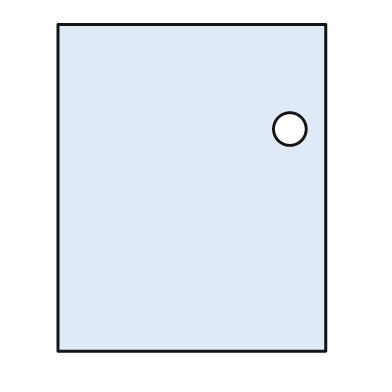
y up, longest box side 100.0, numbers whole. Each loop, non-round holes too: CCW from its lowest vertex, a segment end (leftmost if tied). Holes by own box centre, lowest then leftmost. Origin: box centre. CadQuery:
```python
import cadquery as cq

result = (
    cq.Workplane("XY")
    .moveTo(-41.0, -50.0)
    .lineTo(41.0, -50.0)
    .lineTo(41.0, 50.0)
    .lineTo(-41.0, 50.0)
    .close()
    .moveTo(30.0, 18.0)
    .circle(5.0)
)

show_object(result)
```